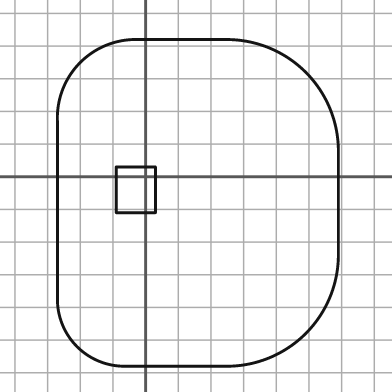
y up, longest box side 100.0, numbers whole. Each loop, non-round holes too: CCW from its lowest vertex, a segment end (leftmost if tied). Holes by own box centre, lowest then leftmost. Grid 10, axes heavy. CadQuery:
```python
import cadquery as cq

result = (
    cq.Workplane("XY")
    .moveTo(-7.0, -58.0)
    .lineTo(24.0, -58.0)
    .threePointArc((49.0, -48.0), (59.0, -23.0))
    .lineTo(59.0, 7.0)
    .threePointArc((49.0, 32.0), (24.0, 42.0))
    .lineTo(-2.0, 42.0)
    .threePointArc((-20.0, 35.0), (-27.0, 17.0))
    .lineTo(-27.0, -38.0)
    .threePointArc((-21.0, -52.0), (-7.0, -58.0))
    .close()
    .moveTo(-9.0, -11.0)
    .lineTo(3.0, -11.0)
    .lineTo(3.0, 3.0)
    .lineTo(-9.0, 3.0)
    .close()
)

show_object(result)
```